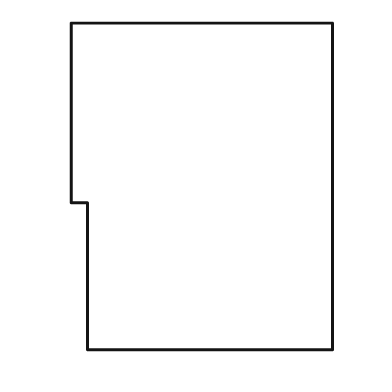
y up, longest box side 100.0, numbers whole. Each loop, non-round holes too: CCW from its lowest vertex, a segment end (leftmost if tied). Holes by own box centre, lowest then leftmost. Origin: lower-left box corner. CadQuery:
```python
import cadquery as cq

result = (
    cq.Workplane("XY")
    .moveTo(5.0, 0.0)
    .lineTo(80.0, 0.0)
    .lineTo(80.0, 100.0)
    .lineTo(0.0, 100.0)
    .lineTo(0.0, 45.0)
    .lineTo(5.0, 45.0)
    .close()
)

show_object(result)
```